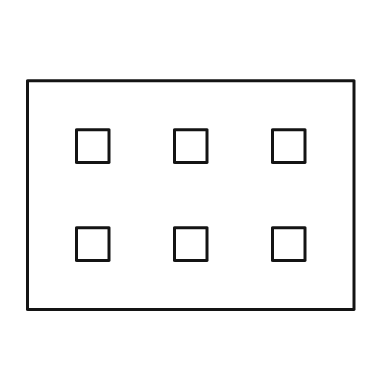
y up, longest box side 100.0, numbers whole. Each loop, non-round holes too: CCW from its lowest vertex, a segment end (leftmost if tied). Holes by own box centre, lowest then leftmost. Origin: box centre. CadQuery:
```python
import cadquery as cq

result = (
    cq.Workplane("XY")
    .moveTo(-50.0, -35.0)
    .lineTo(50.0, -35.0)
    .lineTo(50.0, 35.0)
    .lineTo(-50.0, 35.0)
    .close()
    .moveTo(-35.0, -20.0)
    .lineTo(-25.0, -20.0)
    .lineTo(-25.0, -10.0)
    .lineTo(-35.0, -10.0)
    .close()
    .moveTo(-5.0, -20.0)
    .lineTo(5.0, -20.0)
    .lineTo(5.0, -10.0)
    .lineTo(-5.0, -10.0)
    .close()
    .moveTo(25.0, -20.0)
    .lineTo(35.0, -20.0)
    .lineTo(35.0, -10.0)
    .lineTo(25.0, -10.0)
    .close()
    .moveTo(-35.0, 10.0)
    .lineTo(-25.0, 10.0)
    .lineTo(-25.0, 20.0)
    .lineTo(-35.0, 20.0)
    .close()
    .moveTo(-5.0, 10.0)
    .lineTo(5.0, 10.0)
    .lineTo(5.0, 20.0)
    .lineTo(-5.0, 20.0)
    .close()
    .moveTo(25.0, 10.0)
    .lineTo(35.0, 10.0)
    .lineTo(35.0, 20.0)
    .lineTo(25.0, 20.0)
    .close()
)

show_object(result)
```